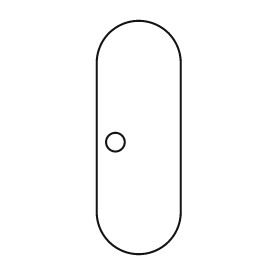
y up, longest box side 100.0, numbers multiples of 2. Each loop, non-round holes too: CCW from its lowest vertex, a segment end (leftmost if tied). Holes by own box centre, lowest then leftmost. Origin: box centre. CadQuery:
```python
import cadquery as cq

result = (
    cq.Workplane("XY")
    .moveTo(-18.0, -32.0)
    .threePointArc((0.0, -50.0), (18.0, -32.0))
    .lineTo(18.0, 32.0)
    .threePointArc((0.0, 50.0), (-18.0, 32.0))
    .close()
    .moveTo(-10.0, -2.0)
    .circle(4.0)
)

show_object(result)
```